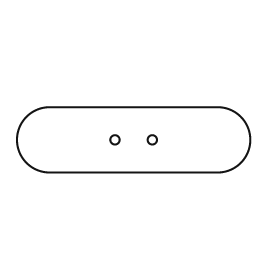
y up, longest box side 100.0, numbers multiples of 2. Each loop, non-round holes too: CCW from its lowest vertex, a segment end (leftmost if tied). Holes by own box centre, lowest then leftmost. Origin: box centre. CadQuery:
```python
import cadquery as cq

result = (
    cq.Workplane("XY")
    .moveTo(-36.0, -14.0)
    .lineTo(36.0, -14.0)
    .threePointArc((50.0, 0.0), (36.0, 14.0))
    .lineTo(-36.0, 14.0)
    .threePointArc((-50.0, 0.0), (-36.0, -14.0))
    .close()
    .moveTo(-8.0, 0.0)
    .circle(2.0)
    .moveTo(8.0, 0.0)
    .circle(2.0)
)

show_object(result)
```